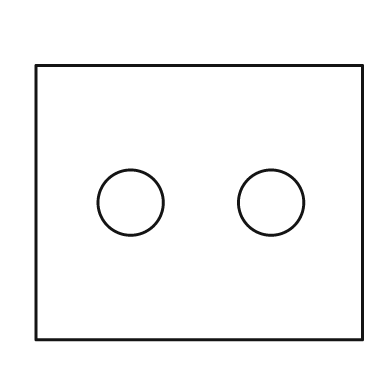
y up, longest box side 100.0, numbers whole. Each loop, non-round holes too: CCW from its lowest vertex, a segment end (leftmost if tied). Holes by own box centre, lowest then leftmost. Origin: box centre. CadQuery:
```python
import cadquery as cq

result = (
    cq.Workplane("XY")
    .moveTo(-50.0, -42.0)
    .lineTo(50.0, -42.0)
    .lineTo(50.0, 42.0)
    .lineTo(-50.0, 42.0)
    .close()
    .moveTo(-21.0, 0.0)
    .circle(10.0)
    .moveTo(22.0, 0.0)
    .circle(10.0)
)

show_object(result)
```